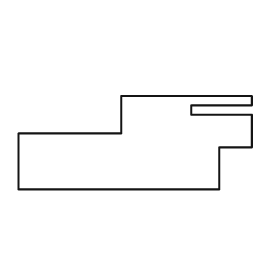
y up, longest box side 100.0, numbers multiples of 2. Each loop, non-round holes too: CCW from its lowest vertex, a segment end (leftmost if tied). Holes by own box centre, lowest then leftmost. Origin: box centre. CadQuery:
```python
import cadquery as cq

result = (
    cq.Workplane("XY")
    .moveTo(-50.0, -20.0)
    .lineTo(36.0, -20.0)
    .lineTo(36.0, -2.0)
    .lineTo(50.0, -2.0)
    .lineTo(50.0, 12.0)
    .lineTo(24.0, 12.0)
    .lineTo(24.0, 16.0)
    .lineTo(50.0, 16.0)
    .lineTo(50.0, 20.0)
    .lineTo(-6.0, 20.0)
    .lineTo(-6.0, 4.0)
    .lineTo(-50.0, 4.0)
    .close()
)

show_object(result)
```